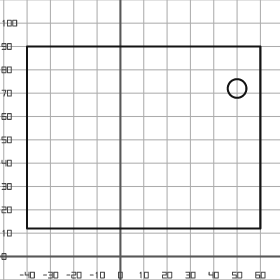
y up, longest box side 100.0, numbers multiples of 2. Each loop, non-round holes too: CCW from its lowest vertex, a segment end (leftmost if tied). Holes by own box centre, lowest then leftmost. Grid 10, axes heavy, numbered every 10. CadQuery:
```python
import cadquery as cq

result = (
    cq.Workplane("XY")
    .moveTo(-40.0, 12.0)
    .lineTo(60.0, 12.0)
    .lineTo(60.0, 90.0)
    .lineTo(-40.0, 90.0)
    .close()
    .moveTo(50.0, 72.0)
    .circle(4.0)
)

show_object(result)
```